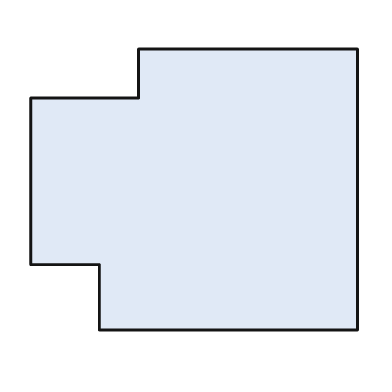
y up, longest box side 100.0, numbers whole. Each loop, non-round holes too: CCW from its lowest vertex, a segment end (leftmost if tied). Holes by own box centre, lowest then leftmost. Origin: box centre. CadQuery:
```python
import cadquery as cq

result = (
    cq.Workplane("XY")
    .moveTo(-29.0, -43.0)
    .lineTo(50.0, -43.0)
    .lineTo(50.0, 43.0)
    .lineTo(-17.0, 43.0)
    .lineTo(-17.0, 28.0)
    .lineTo(-50.0, 28.0)
    .lineTo(-50.0, -23.0)
    .lineTo(-29.0, -23.0)
    .close()
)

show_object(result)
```